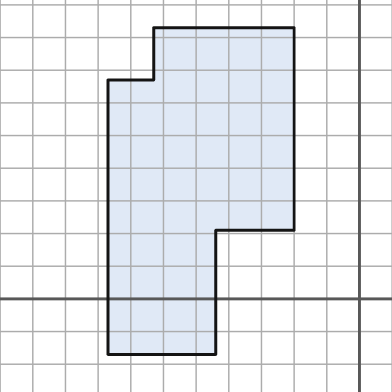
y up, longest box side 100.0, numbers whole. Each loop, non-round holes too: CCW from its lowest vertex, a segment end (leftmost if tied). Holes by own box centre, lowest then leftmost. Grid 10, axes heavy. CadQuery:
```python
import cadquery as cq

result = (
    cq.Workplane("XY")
    .moveTo(-77.0, -17.0)
    .lineTo(-44.0, -17.0)
    .lineTo(-44.0, 21.0)
    .lineTo(-20.0, 21.0)
    .lineTo(-20.0, 83.0)
    .lineTo(-63.0, 83.0)
    .lineTo(-63.0, 67.0)
    .lineTo(-77.0, 67.0)
    .close()
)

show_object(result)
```